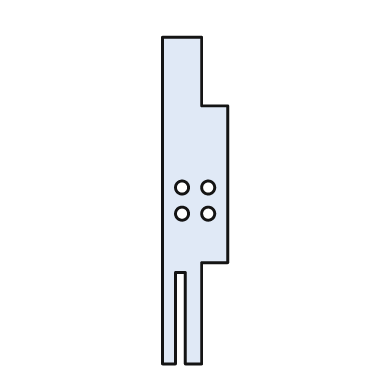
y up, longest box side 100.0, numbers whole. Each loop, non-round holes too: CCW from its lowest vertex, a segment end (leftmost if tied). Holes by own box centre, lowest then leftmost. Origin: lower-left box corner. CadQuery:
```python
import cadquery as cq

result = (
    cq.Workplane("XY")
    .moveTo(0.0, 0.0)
    .lineTo(4.0, 0.0)
    .lineTo(4.0, 28.0)
    .lineTo(7.0, 28.0)
    .lineTo(7.0, 0.0)
    .lineTo(12.0, 0.0)
    .lineTo(12.0, 31.0)
    .lineTo(20.0, 31.0)
    .lineTo(20.0, 79.0)
    .lineTo(12.0, 79.0)
    .lineTo(12.0, 100.0)
    .lineTo(0.0, 100.0)
    .close()
    .moveTo(6.0, 46.0)
    .circle(2.0)
    .moveTo(14.0, 46.0)
    .circle(2.0)
    .moveTo(6.0, 54.0)
    .circle(2.0)
    .moveTo(14.0, 54.0)
    .circle(2.0)
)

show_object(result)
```